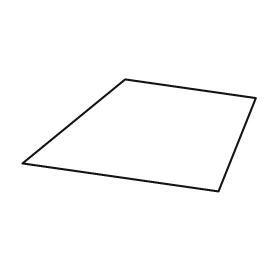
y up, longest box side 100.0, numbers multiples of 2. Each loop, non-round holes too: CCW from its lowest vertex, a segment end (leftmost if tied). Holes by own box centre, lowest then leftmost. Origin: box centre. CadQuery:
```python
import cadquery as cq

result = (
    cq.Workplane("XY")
    .moveTo(34.0, -24.0)
    .lineTo(50.0, 16.0)
    .lineTo(-6.0, 24.0)
    .lineTo(-50.0, -12.0)
    .close()
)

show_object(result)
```